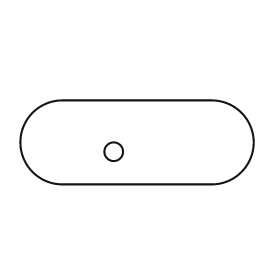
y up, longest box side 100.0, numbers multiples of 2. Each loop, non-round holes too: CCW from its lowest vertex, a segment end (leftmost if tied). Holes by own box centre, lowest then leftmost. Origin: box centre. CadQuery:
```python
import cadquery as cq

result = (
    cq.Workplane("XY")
    .moveTo(-32.0, -18.0)
    .lineTo(32.0, -18.0)
    .threePointArc((50.0, 0.0), (32.0, 18.0))
    .lineTo(-32.0, 18.0)
    .threePointArc((-50.0, 0.0), (-32.0, -18.0))
    .close()
    .moveTo(-10.0, -4.0)
    .circle(4.0)
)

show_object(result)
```